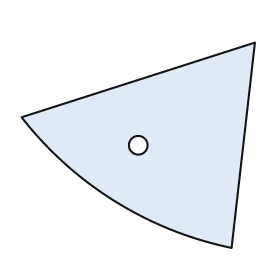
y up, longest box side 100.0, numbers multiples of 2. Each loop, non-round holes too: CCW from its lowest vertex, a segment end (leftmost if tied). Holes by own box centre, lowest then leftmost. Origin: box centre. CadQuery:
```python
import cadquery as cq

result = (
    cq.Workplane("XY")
    .moveTo(40.0, -44.0)
    .lineTo(50.0, 44.0)
    .lineTo(-50.0, 12.0)
    .threePointArc((-10.0, -24.0), (40.0, -44.0))
    .close()
    .moveTo(0.0, 0.0)
    .circle(4.0)
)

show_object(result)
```